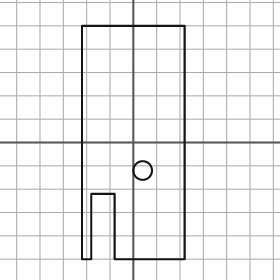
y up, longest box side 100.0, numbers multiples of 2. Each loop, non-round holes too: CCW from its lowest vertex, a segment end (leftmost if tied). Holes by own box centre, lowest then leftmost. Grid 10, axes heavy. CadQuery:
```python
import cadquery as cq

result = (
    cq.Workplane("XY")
    .moveTo(-22.0, -50.0)
    .lineTo(-18.0, -50.0)
    .lineTo(-18.0, -22.0)
    .lineTo(-8.0, -22.0)
    .lineTo(-8.0, -50.0)
    .lineTo(22.0, -50.0)
    .lineTo(22.0, 50.0)
    .lineTo(-22.0, 50.0)
    .close()
    .moveTo(4.0, -12.0)
    .circle(4.0)
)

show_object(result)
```